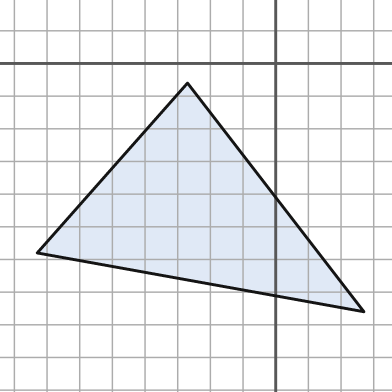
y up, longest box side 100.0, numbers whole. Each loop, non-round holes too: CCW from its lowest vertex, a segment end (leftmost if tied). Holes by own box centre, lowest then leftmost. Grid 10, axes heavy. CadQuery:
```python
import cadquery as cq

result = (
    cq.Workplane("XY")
    .moveTo(27.0, -76.0)
    .lineTo(-27.0, -6.0)
    .lineTo(-73.0, -58.0)
    .close()
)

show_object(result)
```